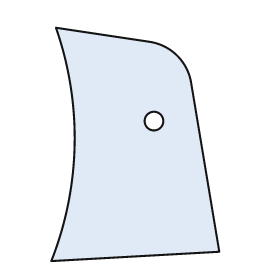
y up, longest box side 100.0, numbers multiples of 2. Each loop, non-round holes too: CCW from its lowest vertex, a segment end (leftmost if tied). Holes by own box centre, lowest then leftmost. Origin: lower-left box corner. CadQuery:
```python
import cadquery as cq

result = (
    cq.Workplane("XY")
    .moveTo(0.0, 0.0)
    .lineTo(72.0, 4.0)
    .lineTo(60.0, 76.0)
    .threePointArc((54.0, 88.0), (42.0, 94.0))
    .lineTo(2.0, 100.0)
    .threePointArc((10.0, 50.0), (0.0, 0.0))
    .close()
    .moveTo(44.0, 60.0)
    .circle(4.0)
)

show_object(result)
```